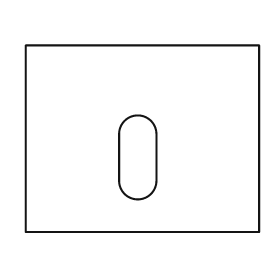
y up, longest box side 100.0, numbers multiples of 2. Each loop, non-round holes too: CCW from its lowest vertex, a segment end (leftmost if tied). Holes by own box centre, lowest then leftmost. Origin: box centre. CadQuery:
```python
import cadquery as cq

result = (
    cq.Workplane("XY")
    .moveTo(-50.0, -40.0)
    .lineTo(50.0, -40.0)
    .lineTo(50.0, 40.0)
    .lineTo(-50.0, 40.0)
    .close()
    .moveTo(-10.0, -18.0)
    .threePointArc((-2.0, -26.0), (6.0, -18.0))
    .lineTo(6.0, 2.0)
    .threePointArc((-2.0, 10.0), (-10.0, 2.0))
    .close()
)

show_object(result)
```